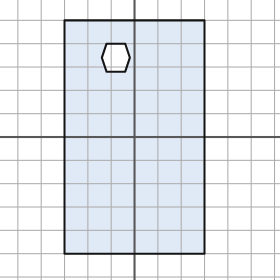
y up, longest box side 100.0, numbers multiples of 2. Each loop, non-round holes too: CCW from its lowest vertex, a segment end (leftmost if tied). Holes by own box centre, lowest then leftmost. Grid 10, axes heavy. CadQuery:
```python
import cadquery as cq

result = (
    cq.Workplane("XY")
    .moveTo(-30.0, -50.0)
    .lineTo(30.0, -50.0)
    .lineTo(30.0, 50.0)
    .lineTo(-30.0, 50.0)
    .close()
    .moveTo(-12.0, 28.0)
    .lineTo(-4.0, 28.0)
    .lineTo(-2.0, 34.0)
    .lineTo(-4.0, 40.0)
    .lineTo(-12.0, 40.0)
    .lineTo(-14.0, 34.0)
    .close()
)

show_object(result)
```